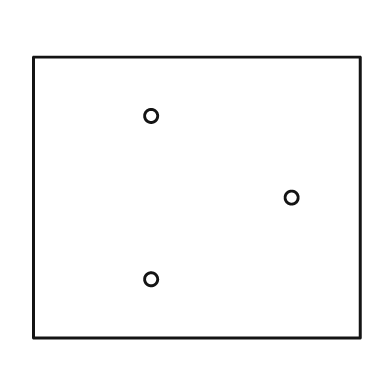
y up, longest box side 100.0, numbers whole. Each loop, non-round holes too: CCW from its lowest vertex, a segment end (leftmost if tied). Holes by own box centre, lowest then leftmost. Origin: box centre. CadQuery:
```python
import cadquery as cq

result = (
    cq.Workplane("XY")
    .moveTo(-50.0, -43.0)
    .lineTo(50.0, -43.0)
    .lineTo(50.0, 43.0)
    .lineTo(-50.0, 43.0)
    .close()
    .moveTo(-14.0, -25.0)
    .circle(2.0)
    .moveTo(29.0, 0.0)
    .circle(2.0)
    .moveTo(-14.0, 25.0)
    .circle(2.0)
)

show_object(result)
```